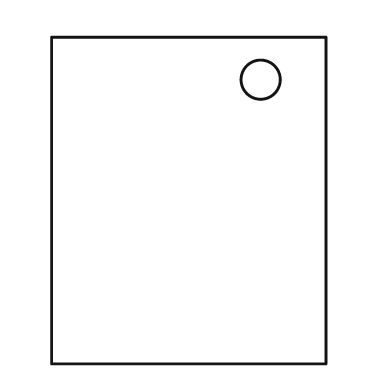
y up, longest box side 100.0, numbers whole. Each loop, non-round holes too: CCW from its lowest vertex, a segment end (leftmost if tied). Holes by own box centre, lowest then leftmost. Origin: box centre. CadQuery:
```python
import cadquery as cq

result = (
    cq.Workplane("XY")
    .moveTo(-42.0, -50.0)
    .lineTo(42.0, -50.0)
    .lineTo(42.0, 50.0)
    .lineTo(-42.0, 50.0)
    .close()
    .moveTo(22.0, 37.0)
    .circle(6.0)
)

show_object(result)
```